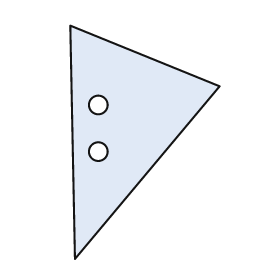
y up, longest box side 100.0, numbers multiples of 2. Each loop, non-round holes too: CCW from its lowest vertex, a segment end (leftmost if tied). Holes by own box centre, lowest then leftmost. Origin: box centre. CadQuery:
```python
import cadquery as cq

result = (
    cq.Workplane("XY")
    .moveTo(-30.0, -50.0)
    .lineTo(32.0, 24.0)
    .lineTo(-32.0, 50.0)
    .close()
    .moveTo(-20.0, -4.0)
    .circle(4.0)
    .moveTo(-20.0, 16.0)
    .circle(4.0)
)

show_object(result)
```